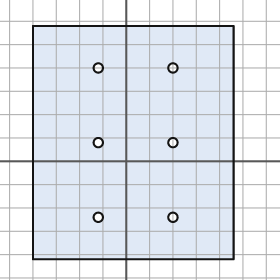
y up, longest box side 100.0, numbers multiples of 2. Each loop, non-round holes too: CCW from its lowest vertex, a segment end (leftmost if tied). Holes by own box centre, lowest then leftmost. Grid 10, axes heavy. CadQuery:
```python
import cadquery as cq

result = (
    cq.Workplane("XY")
    .moveTo(-40.0, -42.0)
    .lineTo(46.0, -42.0)
    .lineTo(46.0, 58.0)
    .lineTo(-40.0, 58.0)
    .close()
    .moveTo(-12.0, -24.0)
    .circle(2.0)
    .moveTo(20.0, -24.0)
    .circle(2.0)
    .moveTo(-12.0, 8.0)
    .circle(2.0)
    .moveTo(20.0, 8.0)
    .circle(2.0)
    .moveTo(-12.0, 40.0)
    .circle(2.0)
    .moveTo(20.0, 40.0)
    .circle(2.0)
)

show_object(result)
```